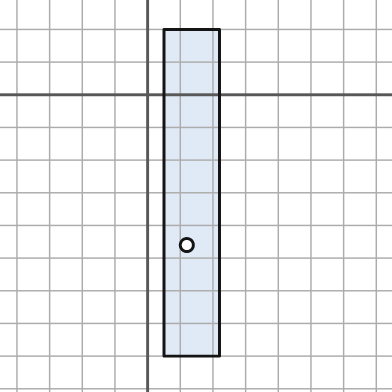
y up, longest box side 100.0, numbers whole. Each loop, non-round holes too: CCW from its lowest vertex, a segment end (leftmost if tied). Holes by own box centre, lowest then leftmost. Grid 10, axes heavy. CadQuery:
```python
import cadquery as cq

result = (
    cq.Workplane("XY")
    .moveTo(5.0, -80.0)
    .lineTo(22.0, -80.0)
    .lineTo(22.0, 20.0)
    .lineTo(5.0, 20.0)
    .close()
    .moveTo(12.0, -46.0)
    .circle(2.0)
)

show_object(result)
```